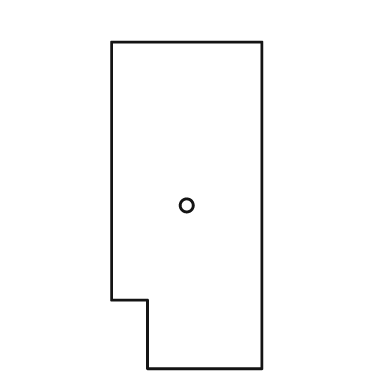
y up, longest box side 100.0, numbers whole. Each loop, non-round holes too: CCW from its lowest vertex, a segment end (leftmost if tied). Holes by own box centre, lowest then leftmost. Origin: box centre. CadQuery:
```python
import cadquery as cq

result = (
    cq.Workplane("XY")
    .moveTo(-12.0, -50.0)
    .lineTo(23.0, -50.0)
    .lineTo(23.0, 50.0)
    .lineTo(-23.0, 50.0)
    .lineTo(-23.0, -29.0)
    .lineTo(-12.0, -29.0)
    .close()
    .moveTo(0.0, 0.0)
    .circle(2.0)
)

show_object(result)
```